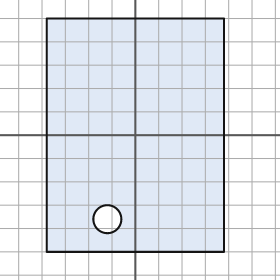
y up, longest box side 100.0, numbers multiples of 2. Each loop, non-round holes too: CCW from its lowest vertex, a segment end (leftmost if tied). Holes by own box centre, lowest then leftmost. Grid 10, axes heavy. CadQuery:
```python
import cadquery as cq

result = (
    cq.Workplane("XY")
    .moveTo(-38.0, -50.0)
    .lineTo(38.0, -50.0)
    .lineTo(38.0, 50.0)
    .lineTo(-38.0, 50.0)
    .close()
    .moveTo(-12.0, -36.0)
    .circle(6.0)
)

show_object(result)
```